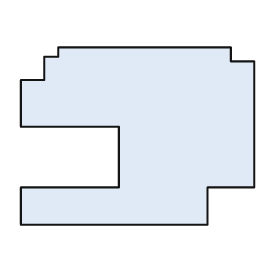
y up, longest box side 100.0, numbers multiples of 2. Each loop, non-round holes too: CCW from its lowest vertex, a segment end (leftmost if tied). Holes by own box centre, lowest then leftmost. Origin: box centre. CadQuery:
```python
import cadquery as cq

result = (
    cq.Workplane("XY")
    .moveTo(-50.0, -38.0)
    .lineTo(30.0, -38.0)
    .lineTo(30.0, -22.0)
    .lineTo(50.0, -22.0)
    .lineTo(50.0, 32.0)
    .lineTo(40.0, 32.0)
    .lineTo(40.0, 38.0)
    .lineTo(-34.0, 38.0)
    .lineTo(-34.0, 34.0)
    .lineTo(-40.0, 34.0)
    .lineTo(-40.0, 24.0)
    .lineTo(-50.0, 24.0)
    .lineTo(-50.0, 4.0)
    .lineTo(-8.0, 4.0)
    .lineTo(-8.0, -22.0)
    .lineTo(-50.0, -22.0)
    .close()
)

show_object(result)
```